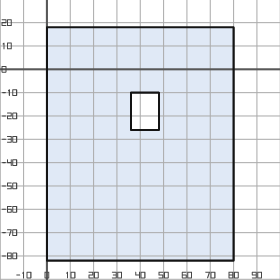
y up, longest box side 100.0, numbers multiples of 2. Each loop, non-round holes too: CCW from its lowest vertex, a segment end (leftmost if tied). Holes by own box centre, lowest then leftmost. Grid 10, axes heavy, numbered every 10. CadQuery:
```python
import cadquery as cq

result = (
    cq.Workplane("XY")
    .moveTo(0.0, -82.0)
    .lineTo(80.0, -82.0)
    .lineTo(80.0, 18.0)
    .lineTo(0.0, 18.0)
    .close()
    .moveTo(36.0, -26.0)
    .lineTo(48.0, -26.0)
    .lineTo(48.0, -10.0)
    .lineTo(36.0, -10.0)
    .close()
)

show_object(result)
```